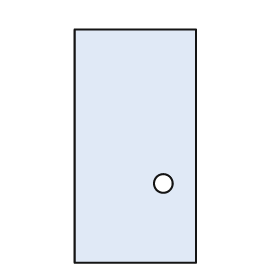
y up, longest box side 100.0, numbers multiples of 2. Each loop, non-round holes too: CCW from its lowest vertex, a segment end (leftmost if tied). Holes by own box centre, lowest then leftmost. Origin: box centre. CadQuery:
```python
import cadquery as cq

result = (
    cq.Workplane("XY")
    .moveTo(-26.0, -50.0)
    .lineTo(26.0, -50.0)
    .lineTo(26.0, 50.0)
    .lineTo(-26.0, 50.0)
    .close()
    .moveTo(12.0, -16.0)
    .circle(4.0)
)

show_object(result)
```